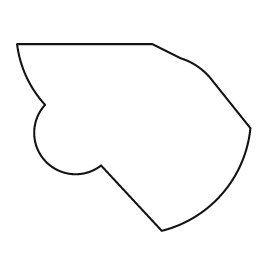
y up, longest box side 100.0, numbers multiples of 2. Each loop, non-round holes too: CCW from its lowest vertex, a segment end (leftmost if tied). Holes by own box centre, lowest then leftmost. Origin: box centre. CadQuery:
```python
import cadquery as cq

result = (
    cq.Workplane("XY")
    .moveTo(12.0, -40.0)
    .threePointArc((38.0, -24.0), (50.0, 4.0))
    .lineTo(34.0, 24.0)
    .threePointArc((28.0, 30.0), (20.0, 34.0))
    .lineTo(8.0, 40.0)
    .lineTo(-50.0, 40.0)
    .threePointArc((-46.0, 26.0), (-38.0, 14.0))
    .threePointArc((-38.0, -10.0), (-14.0, -12.0))
    .close()
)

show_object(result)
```